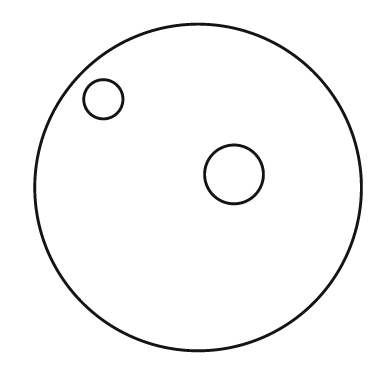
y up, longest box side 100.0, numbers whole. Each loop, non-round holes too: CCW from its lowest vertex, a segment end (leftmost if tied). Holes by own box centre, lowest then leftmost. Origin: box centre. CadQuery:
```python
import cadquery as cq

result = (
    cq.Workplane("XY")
    .moveTo(0.0, 0.0)
    .circle(50.0)
    .moveTo(11.0, 4.0)
    .circle(9.0)
    .moveTo(-29.0, 27.0)
    .circle(6.0)
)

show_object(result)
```